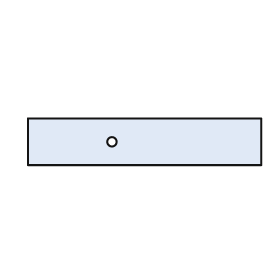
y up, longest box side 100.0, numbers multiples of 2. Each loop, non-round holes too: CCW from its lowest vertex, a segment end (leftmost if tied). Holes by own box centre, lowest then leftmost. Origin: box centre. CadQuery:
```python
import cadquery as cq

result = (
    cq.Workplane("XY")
    .moveTo(-50.0, -10.0)
    .lineTo(50.0, -10.0)
    .lineTo(50.0, 10.0)
    .lineTo(-50.0, 10.0)
    .close()
    .moveTo(-14.0, 0.0)
    .circle(2.0)
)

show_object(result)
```